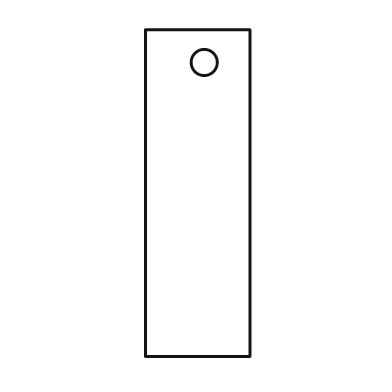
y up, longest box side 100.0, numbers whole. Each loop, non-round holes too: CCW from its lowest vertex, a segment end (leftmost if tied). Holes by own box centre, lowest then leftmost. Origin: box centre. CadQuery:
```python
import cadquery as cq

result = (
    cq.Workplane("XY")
    .moveTo(-16.0, -50.0)
    .lineTo(16.0, -50.0)
    .lineTo(16.0, 50.0)
    .lineTo(-16.0, 50.0)
    .close()
    .moveTo(2.0, 40.0)
    .circle(4.0)
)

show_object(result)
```